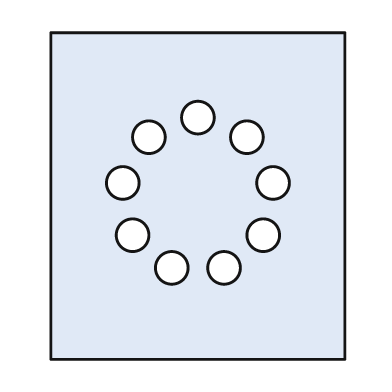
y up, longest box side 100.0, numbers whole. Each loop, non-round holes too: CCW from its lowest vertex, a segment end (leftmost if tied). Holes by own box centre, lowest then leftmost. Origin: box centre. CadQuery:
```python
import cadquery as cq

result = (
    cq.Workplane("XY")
    .moveTo(-45.0, -50.0)
    .lineTo(45.0, -50.0)
    .lineTo(45.0, 50.0)
    .lineTo(-45.0, 50.0)
    .close()
    .moveTo(-8.0, -22.0)
    .circle(5.0)
    .moveTo(8.0, -22.0)
    .circle(5.0)
    .moveTo(-20.0, -12.0)
    .circle(5.0)
    .moveTo(20.0, -12.0)
    .circle(5.0)
    .moveTo(-23.0, 4.0)
    .circle(5.0)
    .moveTo(23.0, 4.0)
    .circle(5.0)
    .moveTo(-15.0, 18.0)
    .circle(5.0)
    .moveTo(15.0, 18.0)
    .circle(5.0)
    .moveTo(0.0, 24.0)
    .circle(5.0)
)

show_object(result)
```